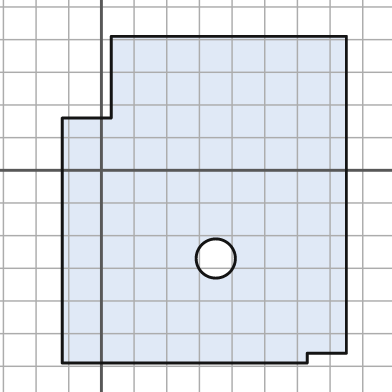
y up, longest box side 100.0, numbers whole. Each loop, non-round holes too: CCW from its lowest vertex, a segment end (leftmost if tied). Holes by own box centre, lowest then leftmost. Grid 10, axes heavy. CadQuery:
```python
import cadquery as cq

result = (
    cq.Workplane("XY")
    .moveTo(-12.0, -59.0)
    .lineTo(63.0, -59.0)
    .lineTo(63.0, -56.0)
    .lineTo(75.0, -56.0)
    .lineTo(75.0, 41.0)
    .lineTo(3.0, 41.0)
    .lineTo(3.0, 16.0)
    .lineTo(-12.0, 16.0)
    .close()
    .moveTo(35.0, -27.0)
    .circle(6.0)
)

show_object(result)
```